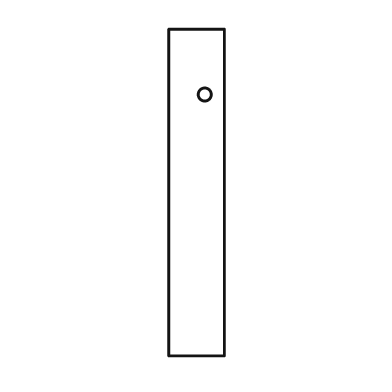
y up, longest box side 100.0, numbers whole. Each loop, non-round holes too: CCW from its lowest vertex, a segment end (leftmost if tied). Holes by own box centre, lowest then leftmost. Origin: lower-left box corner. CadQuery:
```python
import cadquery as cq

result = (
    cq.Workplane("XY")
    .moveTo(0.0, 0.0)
    .lineTo(17.0, 0.0)
    .lineTo(17.0, 100.0)
    .lineTo(0.0, 100.0)
    .close()
    .moveTo(11.0, 80.0)
    .circle(2.0)
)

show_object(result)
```